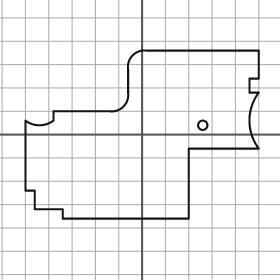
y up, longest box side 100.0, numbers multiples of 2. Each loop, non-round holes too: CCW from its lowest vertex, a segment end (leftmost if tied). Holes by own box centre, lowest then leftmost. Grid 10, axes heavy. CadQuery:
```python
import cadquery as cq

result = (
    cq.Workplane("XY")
    .moveTo(-34.0, -36.0)
    .lineTo(20.0, -36.0)
    .lineTo(20.0, -6.0)
    .lineTo(50.0, -6.0)
    .threePointArc((46.0, 6.0), (50.0, 18.0))
    .lineTo(46.0, 18.0)
    .lineTo(46.0, 24.0)
    .lineTo(50.0, 24.0)
    .lineTo(50.0, 36.0)
    .lineTo(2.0, 36.0)
    .threePointArc((-4.0, 34.0), (-6.0, 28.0))
    .lineTo(-6.0, 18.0)
    .threePointArc((-8.0, 12.0), (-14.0, 10.0))
    .lineTo(-38.0, 10.0)
    .lineTo(-38.0, 6.0)
    .threePointArc((-44.0, 4.0), (-50.0, 6.0))
    .lineTo(-50.0, -24.0)
    .lineTo(-46.0, -24.0)
    .lineTo(-46.0, -32.0)
    .lineTo(-34.0, -32.0)
    .close()
    .moveTo(26.0, 4.0)
    .circle(2.0)
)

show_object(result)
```